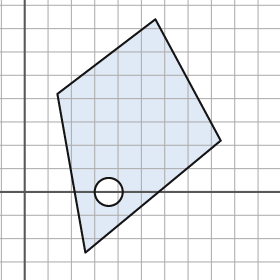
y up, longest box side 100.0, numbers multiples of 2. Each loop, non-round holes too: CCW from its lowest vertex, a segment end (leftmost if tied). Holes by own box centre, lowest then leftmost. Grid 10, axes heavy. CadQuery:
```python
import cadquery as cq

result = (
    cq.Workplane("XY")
    .moveTo(26.0, -26.0)
    .lineTo(84.0, 22.0)
    .lineTo(56.0, 74.0)
    .lineTo(14.0, 42.0)
    .close()
    .moveTo(36.0, 0.0)
    .circle(6.0)
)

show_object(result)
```